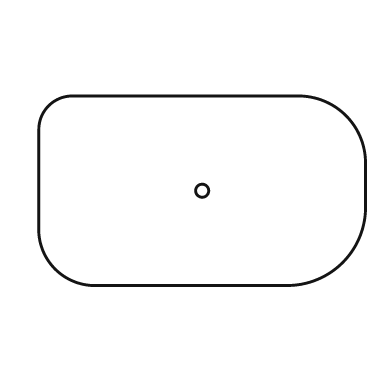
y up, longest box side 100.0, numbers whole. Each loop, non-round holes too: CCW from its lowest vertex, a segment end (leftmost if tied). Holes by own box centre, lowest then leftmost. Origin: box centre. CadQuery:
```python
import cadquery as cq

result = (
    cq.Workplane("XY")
    .moveTo(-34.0, -29.0)
    .lineTo(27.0, -29.0)
    .threePointArc((43.0, -22.0), (50.0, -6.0))
    .lineTo(50.0, 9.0)
    .threePointArc((44.0, 23.0), (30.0, 29.0))
    .lineTo(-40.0, 29.0)
    .threePointArc((-47.0, 26.0), (-50.0, 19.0))
    .lineTo(-50.0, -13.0)
    .threePointArc((-45.0, -24.0), (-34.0, -29.0))
    .close()
    .moveTo(0.0, 0.0)
    .circle(2.0)
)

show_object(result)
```